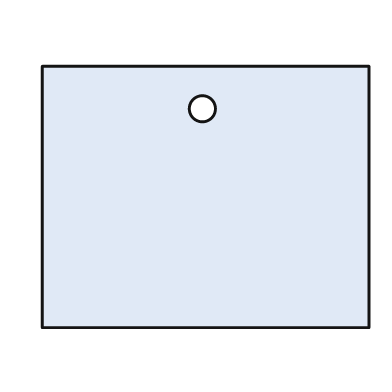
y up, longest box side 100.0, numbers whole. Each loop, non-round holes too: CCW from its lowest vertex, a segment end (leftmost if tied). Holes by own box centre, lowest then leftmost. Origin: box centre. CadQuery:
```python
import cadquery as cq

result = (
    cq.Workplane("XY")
    .moveTo(-50.0, -40.0)
    .lineTo(50.0, -40.0)
    .lineTo(50.0, 40.0)
    .lineTo(-50.0, 40.0)
    .close()
    .moveTo(-1.0, 27.0)
    .circle(4.0)
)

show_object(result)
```